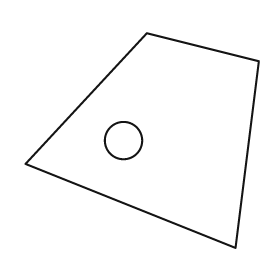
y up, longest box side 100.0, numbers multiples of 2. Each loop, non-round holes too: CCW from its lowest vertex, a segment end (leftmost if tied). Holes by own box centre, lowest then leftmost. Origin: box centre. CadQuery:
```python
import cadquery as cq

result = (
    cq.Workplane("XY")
    .moveTo(40.0, -46.0)
    .lineTo(50.0, 34.0)
    .lineTo(2.0, 46.0)
    .lineTo(-50.0, -10.0)
    .close()
    .moveTo(-8.0, 0.0)
    .circle(8.0)
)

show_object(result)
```